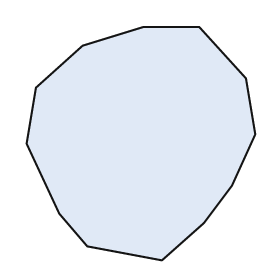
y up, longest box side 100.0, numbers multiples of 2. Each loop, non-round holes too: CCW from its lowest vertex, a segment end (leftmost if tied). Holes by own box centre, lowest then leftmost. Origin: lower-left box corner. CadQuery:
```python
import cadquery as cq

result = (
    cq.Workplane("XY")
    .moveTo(58.0, 0.0)
    .lineTo(76.0, 16.0)
    .lineTo(88.0, 32.0)
    .lineTo(98.0, 54.0)
    .lineTo(94.0, 78.0)
    .lineTo(74.0, 100.0)
    .lineTo(50.0, 100.0)
    .lineTo(24.0, 92.0)
    .lineTo(4.0, 74.0)
    .lineTo(0.0, 50.0)
    .lineTo(14.0, 20.0)
    .lineTo(26.0, 6.0)
    .close()
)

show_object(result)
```